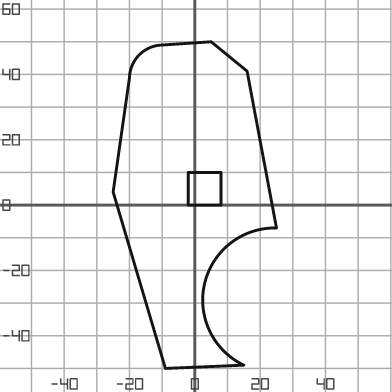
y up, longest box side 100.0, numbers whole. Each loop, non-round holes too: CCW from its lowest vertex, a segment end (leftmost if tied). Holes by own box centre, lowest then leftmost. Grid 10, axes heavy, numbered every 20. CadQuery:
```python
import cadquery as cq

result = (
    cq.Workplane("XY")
    .moveTo(-9.0, -50.0)
    .lineTo(15.0, -49.0)
    .threePointArc((3.0, -24.0), (25.0, -7.0))
    .lineTo(16.0, 41.0)
    .lineTo(5.0, 50.0)
    .lineTo(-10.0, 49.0)
    .threePointArc((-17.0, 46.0), (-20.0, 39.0))
    .lineTo(-25.0, 4.0)
    .close()
    .moveTo(-2.0, 0.0)
    .lineTo(8.0, 0.0)
    .lineTo(8.0, 10.0)
    .lineTo(-2.0, 10.0)
    .close()
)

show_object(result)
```